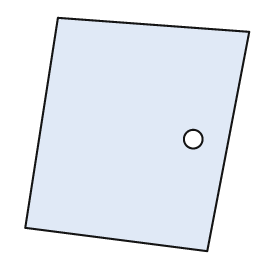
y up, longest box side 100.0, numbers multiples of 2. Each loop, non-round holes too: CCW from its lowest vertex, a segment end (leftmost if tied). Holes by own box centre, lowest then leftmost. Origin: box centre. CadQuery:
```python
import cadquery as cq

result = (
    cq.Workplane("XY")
    .moveTo(30.0, -50.0)
    .lineTo(48.0, 44.0)
    .lineTo(-34.0, 50.0)
    .lineTo(-48.0, -40.0)
    .close()
    .moveTo(24.0, -2.0)
    .circle(4.0)
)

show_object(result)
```